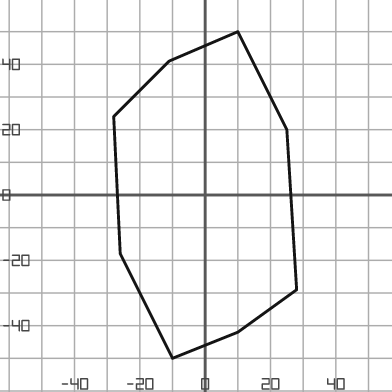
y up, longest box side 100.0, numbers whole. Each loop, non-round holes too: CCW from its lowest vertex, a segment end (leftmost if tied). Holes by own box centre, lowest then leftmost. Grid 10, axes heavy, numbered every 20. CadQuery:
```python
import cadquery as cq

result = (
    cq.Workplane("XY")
    .moveTo(-10.0, -50.0)
    .lineTo(10.0, -42.0)
    .lineTo(28.0, -29.0)
    .lineTo(25.0, 20.0)
    .lineTo(10.0, 50.0)
    .lineTo(-11.0, 41.0)
    .lineTo(-28.0, 24.0)
    .lineTo(-26.0, -18.0)
    .close()
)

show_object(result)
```